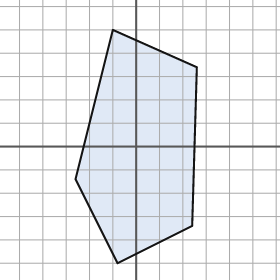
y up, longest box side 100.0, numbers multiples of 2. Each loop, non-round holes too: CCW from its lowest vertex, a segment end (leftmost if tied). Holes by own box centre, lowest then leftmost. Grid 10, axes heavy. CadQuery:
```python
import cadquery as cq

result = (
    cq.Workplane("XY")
    .moveTo(-8.0, -50.0)
    .lineTo(24.0, -34.0)
    .lineTo(26.0, 34.0)
    .lineTo(-10.0, 50.0)
    .lineTo(-26.0, -14.0)
    .close()
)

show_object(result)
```